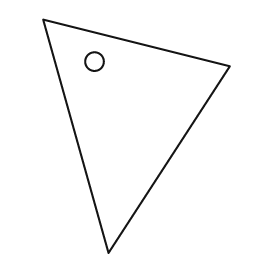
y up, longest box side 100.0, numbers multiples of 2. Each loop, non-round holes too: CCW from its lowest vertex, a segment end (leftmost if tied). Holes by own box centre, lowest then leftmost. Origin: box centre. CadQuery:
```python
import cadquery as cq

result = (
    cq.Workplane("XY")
    .moveTo(-12.0, -50.0)
    .lineTo(40.0, 30.0)
    .lineTo(-40.0, 50.0)
    .close()
    .moveTo(-18.0, 32.0)
    .circle(4.0)
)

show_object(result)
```